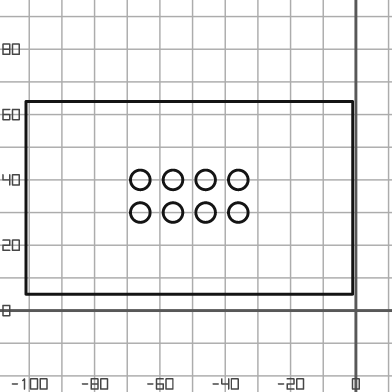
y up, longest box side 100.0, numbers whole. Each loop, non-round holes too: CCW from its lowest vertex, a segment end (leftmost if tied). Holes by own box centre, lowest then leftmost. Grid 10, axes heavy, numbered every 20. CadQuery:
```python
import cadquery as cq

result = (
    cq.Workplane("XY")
    .moveTo(-101.0, 5.0)
    .lineTo(-1.0, 5.0)
    .lineTo(-1.0, 64.0)
    .lineTo(-101.0, 64.0)
    .close()
    .moveTo(-66.0, 30.0)
    .circle(3.0)
    .moveTo(-56.0, 30.0)
    .circle(3.0)
    .moveTo(-46.0, 30.0)
    .circle(3.0)
    .moveTo(-36.0, 30.0)
    .circle(3.0)
    .moveTo(-66.0, 40.0)
    .circle(3.0)
    .moveTo(-56.0, 40.0)
    .circle(3.0)
    .moveTo(-46.0, 40.0)
    .circle(3.0)
    .moveTo(-36.0, 40.0)
    .circle(3.0)
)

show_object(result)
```